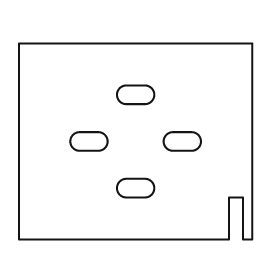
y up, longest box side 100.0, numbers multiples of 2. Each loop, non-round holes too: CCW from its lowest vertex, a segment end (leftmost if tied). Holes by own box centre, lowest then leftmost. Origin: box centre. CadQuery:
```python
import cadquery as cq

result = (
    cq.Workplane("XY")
    .moveTo(-50.0, -42.0)
    .lineTo(40.0, -42.0)
    .lineTo(40.0, -24.0)
    .lineTo(46.0, -24.0)
    .lineTo(46.0, -42.0)
    .lineTo(50.0, -42.0)
    .lineTo(50.0, 42.0)
    .lineTo(-50.0, 42.0)
    .close()
    .moveTo(-4.0, -24.0)
    .lineTo(4.0, -24.0)
    .threePointArc((8.0, -20.0), (4.0, -16.0))
    .lineTo(-4.0, -16.0)
    .threePointArc((-8.0, -20.0), (-4.0, -24.0))
    .close()
    .moveTo(-24.0, -4.0)
    .lineTo(-16.0, -4.0)
    .threePointArc((-12.0, 0.0), (-16.0, 4.0))
    .lineTo(-24.0, 4.0)
    .threePointArc((-28.0, 0.0), (-24.0, -4.0))
    .close()
    .moveTo(16.0, -4.0)
    .lineTo(24.0, -4.0)
    .threePointArc((28.0, 0.0), (24.0, 4.0))
    .lineTo(16.0, 4.0)
    .threePointArc((12.0, 0.0), (16.0, -4.0))
    .close()
    .moveTo(-4.0, 16.0)
    .lineTo(4.0, 16.0)
    .threePointArc((8.0, 20.0), (4.0, 24.0))
    .lineTo(-4.0, 24.0)
    .threePointArc((-8.0, 20.0), (-4.0, 16.0))
    .close()
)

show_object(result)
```